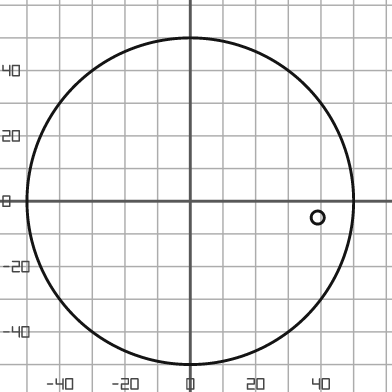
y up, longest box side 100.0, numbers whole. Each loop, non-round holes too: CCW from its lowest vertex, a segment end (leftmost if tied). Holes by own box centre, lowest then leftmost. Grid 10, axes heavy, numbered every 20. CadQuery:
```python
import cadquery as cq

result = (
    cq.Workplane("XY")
    .moveTo(0.0, 0.0)
    .circle(50.0)
    .moveTo(39.0, -5.0)
    .circle(2.0)
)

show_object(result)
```